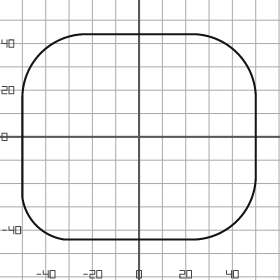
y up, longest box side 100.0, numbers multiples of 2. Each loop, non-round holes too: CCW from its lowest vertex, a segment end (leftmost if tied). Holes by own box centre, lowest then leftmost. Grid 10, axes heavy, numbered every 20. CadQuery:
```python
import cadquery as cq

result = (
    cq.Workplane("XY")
    .moveTo(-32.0, -44.0)
    .lineTo(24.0, -44.0)
    .threePointArc((42.0, -36.0), (50.0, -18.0))
    .lineTo(50.0, 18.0)
    .threePointArc((42.0, 36.0), (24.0, 44.0))
    .lineTo(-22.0, 44.0)
    .threePointArc((-42.0, 36.0), (-50.0, 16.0))
    .lineTo(-50.0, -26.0)
    .threePointArc((-44.0, -38.0), (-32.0, -44.0))
    .close()
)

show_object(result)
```